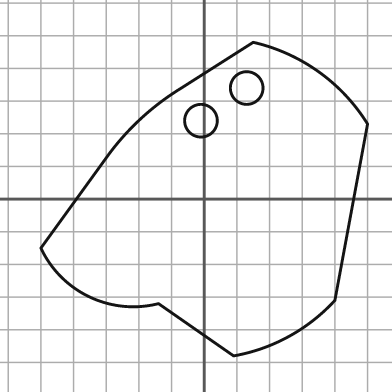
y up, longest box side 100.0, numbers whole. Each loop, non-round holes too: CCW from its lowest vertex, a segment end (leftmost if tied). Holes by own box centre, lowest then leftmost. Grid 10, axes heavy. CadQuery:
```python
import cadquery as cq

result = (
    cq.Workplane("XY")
    .moveTo(9.0, -48.0)
    .threePointArc((26.0, -42.0), (40.0, -31.0))
    .lineTo(50.0, 23.0)
    .threePointArc((35.0, 39.0), (15.0, 48.0))
    .lineTo(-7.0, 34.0)
    .threePointArc((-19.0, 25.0), (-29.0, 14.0))
    .lineTo(-50.0, -15.0)
    .threePointArc((-35.0, -30.0), (-14.0, -32.0))
    .close()
    .moveTo(-1.0, 24.0)
    .circle(5.0)
    .moveTo(13.0, 34.0)
    .circle(5.0)
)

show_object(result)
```